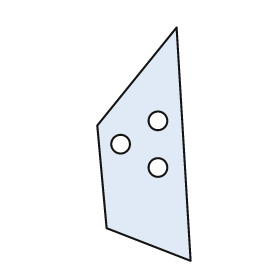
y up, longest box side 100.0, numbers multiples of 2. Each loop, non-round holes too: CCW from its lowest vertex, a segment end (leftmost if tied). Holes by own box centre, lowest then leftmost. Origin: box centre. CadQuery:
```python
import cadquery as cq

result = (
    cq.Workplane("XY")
    .moveTo(20.0, -50.0)
    .lineTo(14.0, 50.0)
    .lineTo(-20.0, 8.0)
    .lineTo(-16.0, -36.0)
    .close()
    .moveTo(6.0, -10.0)
    .circle(4.0)
    .moveTo(-10.0, 0.0)
    .circle(4.0)
    .moveTo(6.0, 10.0)
    .circle(4.0)
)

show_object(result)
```